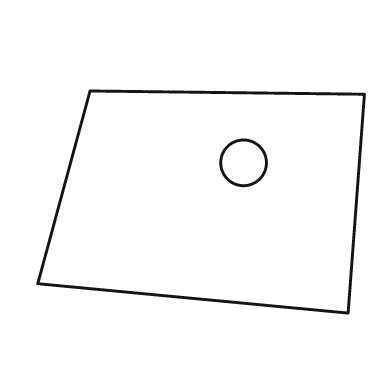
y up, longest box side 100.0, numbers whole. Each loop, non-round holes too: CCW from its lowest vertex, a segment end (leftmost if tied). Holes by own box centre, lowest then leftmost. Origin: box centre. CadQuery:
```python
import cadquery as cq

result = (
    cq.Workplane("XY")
    .moveTo(45.0, -34.0)
    .lineTo(50.0, 33.0)
    .lineTo(-34.0, 34.0)
    .lineTo(-50.0, -25.0)
    .close()
    .moveTo(13.0, 12.0)
    .circle(7.0)
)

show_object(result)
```